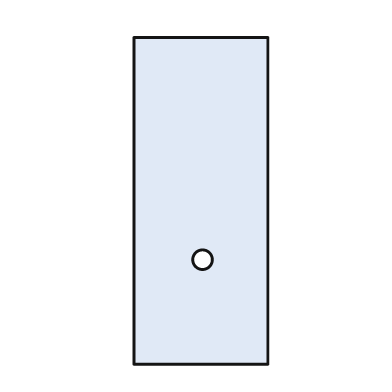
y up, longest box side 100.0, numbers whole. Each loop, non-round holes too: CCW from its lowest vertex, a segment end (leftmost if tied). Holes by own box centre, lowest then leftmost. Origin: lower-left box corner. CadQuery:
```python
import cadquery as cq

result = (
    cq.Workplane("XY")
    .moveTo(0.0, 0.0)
    .lineTo(41.0, 0.0)
    .lineTo(41.0, 100.0)
    .lineTo(0.0, 100.0)
    .close()
    .moveTo(21.0, 32.0)
    .circle(3.0)
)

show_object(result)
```